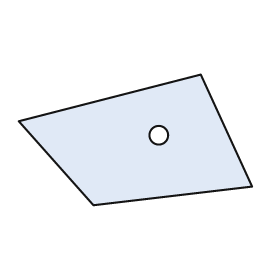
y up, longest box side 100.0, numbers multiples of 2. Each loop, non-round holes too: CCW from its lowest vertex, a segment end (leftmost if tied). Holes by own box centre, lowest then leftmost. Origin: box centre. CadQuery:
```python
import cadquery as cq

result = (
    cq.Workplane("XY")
    .moveTo(-18.0, -28.0)
    .lineTo(50.0, -20.0)
    .lineTo(28.0, 28.0)
    .lineTo(-50.0, 8.0)
    .close()
    .moveTo(10.0, 2.0)
    .circle(4.0)
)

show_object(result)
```